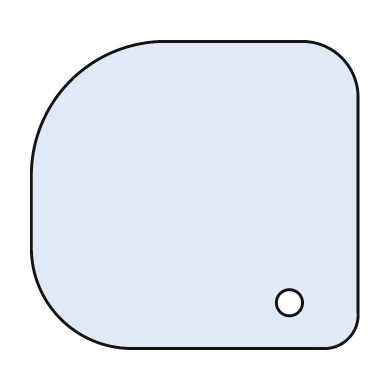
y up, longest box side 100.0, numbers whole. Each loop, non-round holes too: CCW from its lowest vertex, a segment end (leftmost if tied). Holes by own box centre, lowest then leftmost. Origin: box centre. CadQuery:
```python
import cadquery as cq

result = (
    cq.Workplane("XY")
    .moveTo(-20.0, -47.0)
    .lineTo(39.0, -47.0)
    .threePointArc((47.0, -44.0), (50.0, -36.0))
    .lineTo(50.0, 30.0)
    .threePointArc((45.0, 42.0), (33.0, 47.0))
    .lineTo(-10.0, 47.0)
    .threePointArc((-38.0, 35.0), (-50.0, 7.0))
    .lineTo(-50.0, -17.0)
    .threePointArc((-41.0, -38.0), (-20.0, -47.0))
    .close()
    .moveTo(29.0, -33.0)
    .circle(4.0)
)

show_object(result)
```